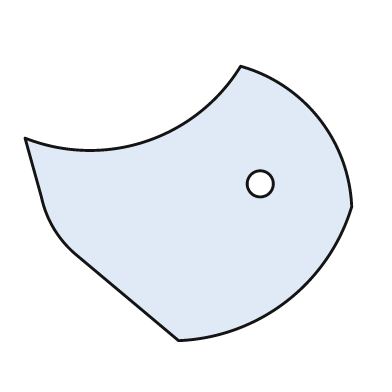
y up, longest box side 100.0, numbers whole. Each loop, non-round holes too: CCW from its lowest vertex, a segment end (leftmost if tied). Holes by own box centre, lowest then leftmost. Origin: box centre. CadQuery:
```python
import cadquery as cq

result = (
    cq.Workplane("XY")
    .moveTo(-3.0, -42.0)
    .threePointArc((30.0, -30.0), (50.0, -1.0))
    .threePointArc((40.0, 26.0), (16.0, 42.0))
    .threePointArc((-13.0, 19.0), (-50.0, 20.0))
    .lineTo(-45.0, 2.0)
    .threePointArc((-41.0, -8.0), (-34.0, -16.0))
    .close()
    .moveTo(22.0, 6.0)
    .circle(4.0)
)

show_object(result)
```